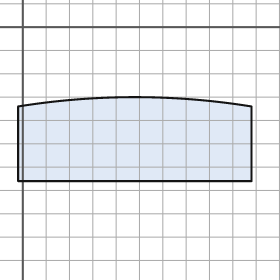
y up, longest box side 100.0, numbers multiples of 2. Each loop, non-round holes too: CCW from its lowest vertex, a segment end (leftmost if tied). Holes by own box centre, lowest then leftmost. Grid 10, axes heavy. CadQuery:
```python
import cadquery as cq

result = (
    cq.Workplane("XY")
    .moveTo(-2.0, -66.0)
    .lineTo(98.0, -66.0)
    .lineTo(98.0, -34.0)
    .threePointArc((48.0, -30.0), (-2.0, -34.0))
    .close()
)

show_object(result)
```